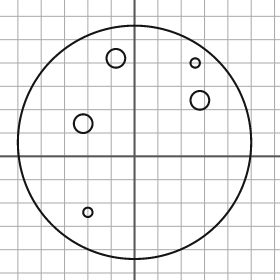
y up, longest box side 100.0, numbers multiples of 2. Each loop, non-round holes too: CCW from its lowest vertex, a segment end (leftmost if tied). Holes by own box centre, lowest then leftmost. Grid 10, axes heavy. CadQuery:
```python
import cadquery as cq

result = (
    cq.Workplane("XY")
    .moveTo(0.0, 6.0)
    .circle(50.0)
    .moveTo(-20.0, -24.0)
    .circle(2.0)
    .moveTo(-22.0, 14.0)
    .circle(4.0)
    .moveTo(28.0, 24.0)
    .circle(4.0)
    .moveTo(26.0, 40.0)
    .circle(2.0)
    .moveTo(-8.0, 42.0)
    .circle(4.0)
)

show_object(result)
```